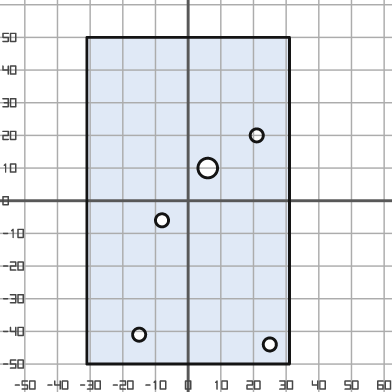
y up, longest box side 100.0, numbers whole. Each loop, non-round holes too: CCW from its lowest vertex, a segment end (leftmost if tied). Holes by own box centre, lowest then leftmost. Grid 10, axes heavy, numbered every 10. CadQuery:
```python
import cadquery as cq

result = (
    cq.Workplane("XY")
    .moveTo(-31.0, -50.0)
    .lineTo(31.0, -50.0)
    .lineTo(31.0, 50.0)
    .lineTo(-31.0, 50.0)
    .close()
    .moveTo(25.0, -44.0)
    .circle(2.0)
    .moveTo(-15.0, -41.0)
    .circle(2.0)
    .moveTo(-8.0, -6.0)
    .circle(2.0)
    .moveTo(6.0, 10.0)
    .circle(3.0)
    .moveTo(21.0, 20.0)
    .circle(2.0)
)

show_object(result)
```